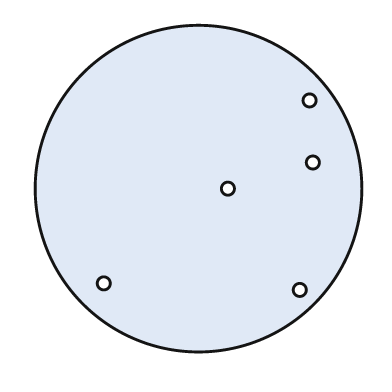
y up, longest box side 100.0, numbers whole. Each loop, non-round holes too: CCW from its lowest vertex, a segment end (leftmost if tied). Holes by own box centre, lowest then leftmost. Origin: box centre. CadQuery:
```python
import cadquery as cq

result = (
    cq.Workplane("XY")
    .moveTo(0.0, 0.0)
    .circle(50.0)
    .moveTo(31.0, -31.0)
    .circle(2.0)
    .moveTo(-29.0, -29.0)
    .circle(2.0)
    .moveTo(9.0, 0.0)
    .circle(2.0)
    .moveTo(35.0, 8.0)
    .circle(2.0)
    .moveTo(34.0, 27.0)
    .circle(2.0)
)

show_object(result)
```